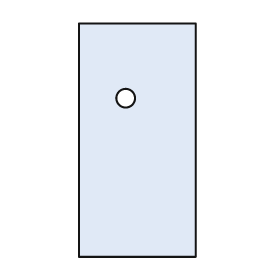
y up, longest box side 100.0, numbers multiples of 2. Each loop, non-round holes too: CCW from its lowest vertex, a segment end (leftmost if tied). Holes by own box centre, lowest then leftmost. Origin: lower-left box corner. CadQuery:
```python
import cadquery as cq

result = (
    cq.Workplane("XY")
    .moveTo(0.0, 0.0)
    .lineTo(50.0, 0.0)
    .lineTo(50.0, 100.0)
    .lineTo(0.0, 100.0)
    .close()
    .moveTo(20.0, 68.0)
    .circle(4.0)
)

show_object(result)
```